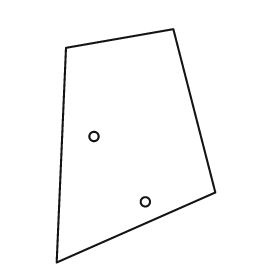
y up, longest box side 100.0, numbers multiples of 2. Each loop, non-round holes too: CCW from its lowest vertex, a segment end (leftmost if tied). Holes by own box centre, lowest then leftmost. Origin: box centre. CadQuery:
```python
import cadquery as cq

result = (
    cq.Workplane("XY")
    .moveTo(-34.0, -50.0)
    .lineTo(34.0, -20.0)
    .lineTo(16.0, 50.0)
    .lineTo(-30.0, 42.0)
    .close()
    .moveTo(4.0, -24.0)
    .circle(2.0)
    .moveTo(-18.0, 4.0)
    .circle(2.0)
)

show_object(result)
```